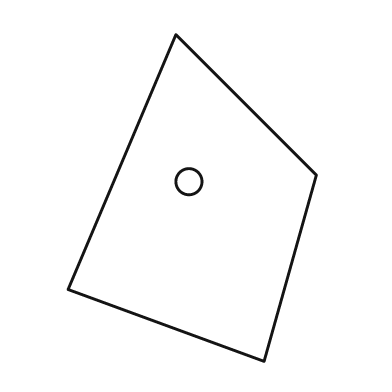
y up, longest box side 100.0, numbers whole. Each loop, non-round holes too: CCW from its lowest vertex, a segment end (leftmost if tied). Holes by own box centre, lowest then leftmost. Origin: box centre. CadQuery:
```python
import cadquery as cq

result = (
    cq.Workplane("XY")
    .moveTo(22.0, -50.0)
    .lineTo(38.0, 7.0)
    .lineTo(-5.0, 50.0)
    .lineTo(-38.0, -28.0)
    .close()
    .moveTo(-1.0, 5.0)
    .circle(4.0)
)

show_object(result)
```